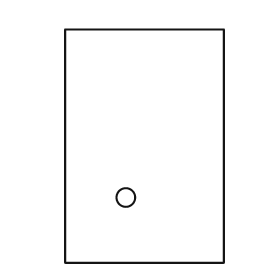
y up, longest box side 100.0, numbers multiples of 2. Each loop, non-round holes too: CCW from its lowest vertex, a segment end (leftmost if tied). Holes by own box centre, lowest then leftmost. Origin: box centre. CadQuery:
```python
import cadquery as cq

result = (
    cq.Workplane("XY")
    .moveTo(-34.0, -50.0)
    .lineTo(34.0, -50.0)
    .lineTo(34.0, 50.0)
    .lineTo(-34.0, 50.0)
    .close()
    .moveTo(-8.0, -22.0)
    .circle(4.0)
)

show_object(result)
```